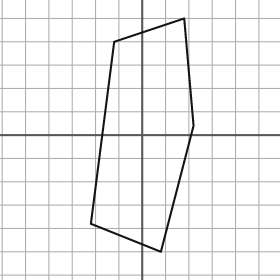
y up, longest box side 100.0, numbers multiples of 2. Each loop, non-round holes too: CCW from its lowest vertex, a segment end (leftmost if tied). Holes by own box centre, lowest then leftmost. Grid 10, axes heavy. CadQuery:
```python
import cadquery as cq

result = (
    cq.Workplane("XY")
    .moveTo(8.0, -50.0)
    .lineTo(22.0, 4.0)
    .lineTo(18.0, 50.0)
    .lineTo(-12.0, 40.0)
    .lineTo(-22.0, -38.0)
    .close()
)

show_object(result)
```